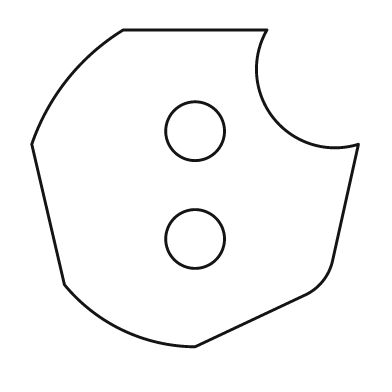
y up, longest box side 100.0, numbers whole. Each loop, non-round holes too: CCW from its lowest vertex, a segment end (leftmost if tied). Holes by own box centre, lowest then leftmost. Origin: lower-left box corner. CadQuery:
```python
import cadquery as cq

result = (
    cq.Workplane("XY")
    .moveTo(50.0, 0.0)
    .lineTo(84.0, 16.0)
    .threePointArc((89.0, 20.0), (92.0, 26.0))
    .lineTo(100.0, 62.0)
    .threePointArc((74.0, 70.0), (72.0, 97.0))
    .lineTo(28.0, 97.0)
    .threePointArc((11.0, 82.0), (0.0, 62.0))
    .lineTo(10.0, 19.0)
    .threePointArc((28.0, 5.0), (50.0, 0.0))
    .close()
    .moveTo(50.0, 33.0)
    .circle(9.0)
    .moveTo(50.0, 66.0)
    .circle(9.0)
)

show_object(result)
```